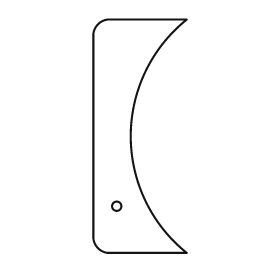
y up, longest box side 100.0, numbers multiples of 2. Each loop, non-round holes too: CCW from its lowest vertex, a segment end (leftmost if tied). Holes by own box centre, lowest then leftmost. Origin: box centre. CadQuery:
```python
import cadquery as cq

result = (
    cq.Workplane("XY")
    .moveTo(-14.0, -50.0)
    .lineTo(20.0, -50.0)
    .threePointArc((-4.0, 0.0), (20.0, 50.0))
    .lineTo(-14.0, 50.0)
    .threePointArc((-18.0, 48.0), (-20.0, 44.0))
    .lineTo(-20.0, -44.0)
    .threePointArc((-18.0, -48.0), (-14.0, -50.0))
    .close()
    .moveTo(-10.0, -30.0)
    .circle(2.0)
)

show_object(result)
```